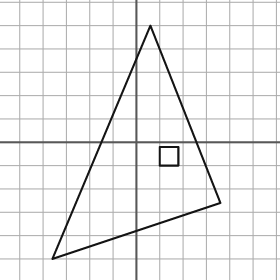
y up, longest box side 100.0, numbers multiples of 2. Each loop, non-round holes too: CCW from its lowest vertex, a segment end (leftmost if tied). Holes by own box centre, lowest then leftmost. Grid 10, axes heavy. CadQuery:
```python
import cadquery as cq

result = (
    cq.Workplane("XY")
    .moveTo(-36.0, -50.0)
    .lineTo(36.0, -26.0)
    .lineTo(6.0, 50.0)
    .close()
    .moveTo(10.0, -10.0)
    .lineTo(18.0, -10.0)
    .lineTo(18.0, -2.0)
    .lineTo(10.0, -2.0)
    .close()
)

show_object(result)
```